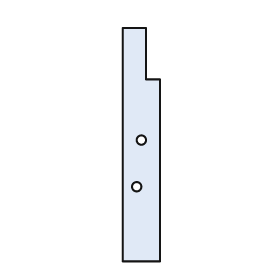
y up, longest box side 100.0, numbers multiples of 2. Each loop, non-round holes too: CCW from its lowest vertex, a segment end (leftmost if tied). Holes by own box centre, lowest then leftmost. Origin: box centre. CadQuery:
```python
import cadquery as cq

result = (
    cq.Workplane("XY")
    .moveTo(-8.0, -50.0)
    .lineTo(8.0, -50.0)
    .lineTo(8.0, 28.0)
    .lineTo(2.0, 28.0)
    .lineTo(2.0, 50.0)
    .lineTo(-8.0, 50.0)
    .close()
    .moveTo(-2.0, -18.0)
    .circle(2.0)
    .moveTo(0.0, 2.0)
    .circle(2.0)
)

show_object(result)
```